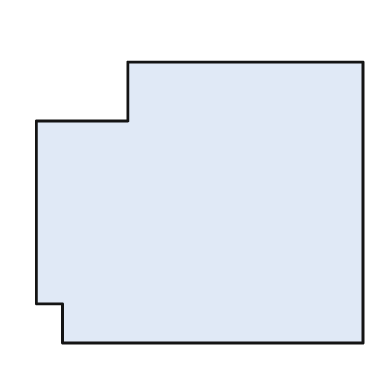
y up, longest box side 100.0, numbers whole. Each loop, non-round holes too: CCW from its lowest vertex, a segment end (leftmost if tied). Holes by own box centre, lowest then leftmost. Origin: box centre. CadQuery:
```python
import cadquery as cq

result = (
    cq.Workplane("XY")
    .moveTo(-42.0, -43.0)
    .lineTo(50.0, -43.0)
    .lineTo(50.0, 43.0)
    .lineTo(-22.0, 43.0)
    .lineTo(-22.0, 25.0)
    .lineTo(-50.0, 25.0)
    .lineTo(-50.0, -31.0)
    .lineTo(-42.0, -31.0)
    .close()
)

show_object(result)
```